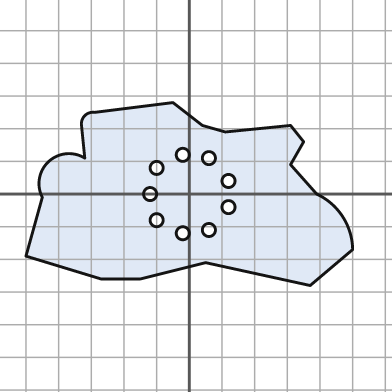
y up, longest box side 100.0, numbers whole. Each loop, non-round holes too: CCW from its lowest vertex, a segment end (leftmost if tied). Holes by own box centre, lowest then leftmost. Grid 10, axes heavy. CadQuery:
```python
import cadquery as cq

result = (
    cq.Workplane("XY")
    .moveTo(37.0, -28.0)
    .lineTo(50.0, -17.0)
    .threePointArc((47.0, -7.0), (39.0, 0.0))
    .lineTo(31.0, 9.0)
    .lineTo(35.0, 16.0)
    .lineTo(31.0, 21.0)
    .lineTo(11.0, 19.0)
    .lineTo(4.0, 21.0)
    .lineTo(-5.0, 28.0)
    .lineTo(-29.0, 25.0)
    .threePointArc((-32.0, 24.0), (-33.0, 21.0))
    .lineTo(-32.0, 11.0)
    .threePointArc((-43.0, 10.0), (-45.0, -1.0))
    .lineTo(-50.0, -19.0)
    .lineTo(-27.0, -26.0)
    .lineTo(-15.0, -26.0)
    .lineTo(5.0, -21.0)
    .close()
    .moveTo(-2.0, -12.0)
    .circle(2.0)
    .moveTo(6.0, -11.0)
    .circle(2.0)
    .moveTo(-10.0, -8.0)
    .circle(2.0)
    .moveTo(12.0, -4.0)
    .circle(2.0)
    .moveTo(-12.0, 0.0)
    .circle(2.0)
    .moveTo(12.0, 4.0)
    .circle(2.0)
    .moveTo(-10.0, 8.0)
    .circle(2.0)
    .moveTo(6.0, 11.0)
    .circle(2.0)
    .moveTo(-2.0, 12.0)
    .circle(2.0)
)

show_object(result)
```